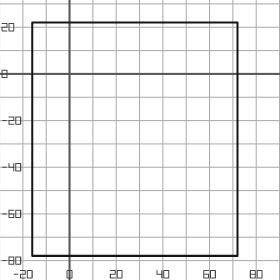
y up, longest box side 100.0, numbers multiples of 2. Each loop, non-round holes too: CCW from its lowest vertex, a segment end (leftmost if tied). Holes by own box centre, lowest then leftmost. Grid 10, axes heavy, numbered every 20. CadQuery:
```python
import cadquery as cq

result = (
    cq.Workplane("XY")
    .moveTo(-16.0, -78.0)
    .lineTo(72.0, -78.0)
    .lineTo(72.0, 22.0)
    .lineTo(-16.0, 22.0)
    .close()
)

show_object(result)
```